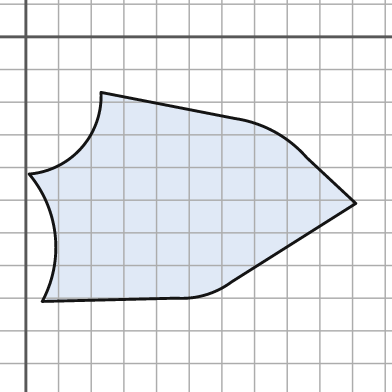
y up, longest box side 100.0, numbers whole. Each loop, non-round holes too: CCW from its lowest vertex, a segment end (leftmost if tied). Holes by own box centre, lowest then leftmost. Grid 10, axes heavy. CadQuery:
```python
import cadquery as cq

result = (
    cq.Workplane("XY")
    .moveTo(5.0, -81.0)
    .lineTo(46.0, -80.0)
    .threePointArc((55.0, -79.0), (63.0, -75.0))
    .lineTo(101.0, -51.0)
    .lineTo(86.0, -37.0)
    .threePointArc((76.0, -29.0), (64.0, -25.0))
    .lineTo(23.0, -17.0)
    .threePointArc((17.0, -34.0), (1.0, -42.0))
    .threePointArc((9.0, -61.0), (5.0, -81.0))
    .close()
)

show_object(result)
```